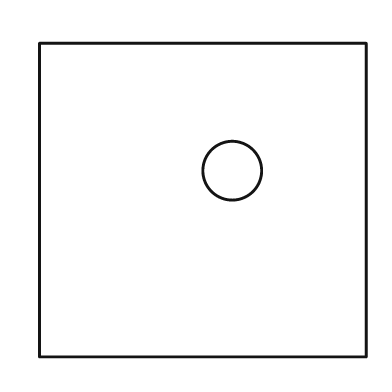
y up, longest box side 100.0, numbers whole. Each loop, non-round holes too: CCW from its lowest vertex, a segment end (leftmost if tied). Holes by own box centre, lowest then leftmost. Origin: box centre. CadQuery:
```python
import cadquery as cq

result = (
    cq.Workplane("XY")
    .moveTo(-50.0, -48.0)
    .lineTo(50.0, -48.0)
    .lineTo(50.0, 48.0)
    .lineTo(-50.0, 48.0)
    .close()
    .moveTo(9.0, 9.0)
    .circle(9.0)
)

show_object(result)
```